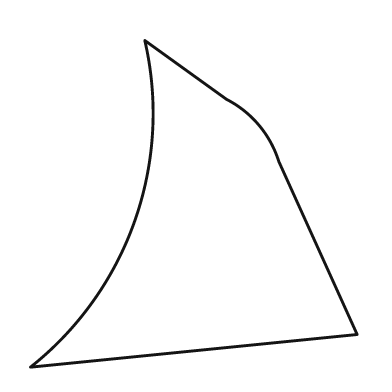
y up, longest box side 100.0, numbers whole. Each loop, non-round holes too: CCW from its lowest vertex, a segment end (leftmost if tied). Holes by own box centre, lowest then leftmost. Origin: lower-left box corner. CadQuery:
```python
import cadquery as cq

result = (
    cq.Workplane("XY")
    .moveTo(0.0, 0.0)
    .lineTo(100.0, 10.0)
    .lineTo(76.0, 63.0)
    .threePointArc((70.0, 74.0), (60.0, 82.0))
    .lineTo(35.0, 100.0)
    .threePointArc((32.0, 45.0), (0.0, 0.0))
    .close()
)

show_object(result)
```